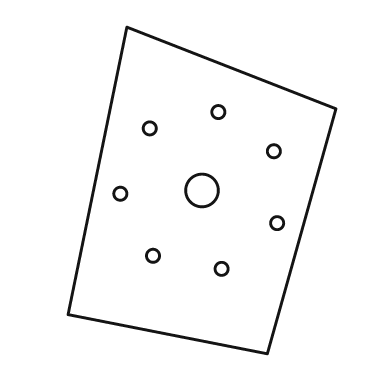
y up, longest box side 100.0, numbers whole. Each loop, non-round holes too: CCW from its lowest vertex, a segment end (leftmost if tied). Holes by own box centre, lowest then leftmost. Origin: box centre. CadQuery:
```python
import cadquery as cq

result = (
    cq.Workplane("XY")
    .moveTo(20.0, -50.0)
    .lineTo(41.0, 25.0)
    .lineTo(-23.0, 50.0)
    .lineTo(-41.0, -38.0)
    .close()
    .moveTo(6.0, -24.0)
    .circle(2.0)
    .moveTo(-15.0, -20.0)
    .circle(2.0)
    .moveTo(23.0, -10.0)
    .circle(2.0)
    .moveTo(-25.0, -1.0)
    .circle(2.0)
    .moveTo(0.0, 0.0)
    .circle(5.0)
    .moveTo(22.0, 12.0)
    .circle(2.0)
    .moveTo(-16.0, 19.0)
    .circle(2.0)
    .moveTo(5.0, 24.0)
    .circle(2.0)
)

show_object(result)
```